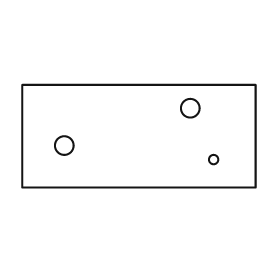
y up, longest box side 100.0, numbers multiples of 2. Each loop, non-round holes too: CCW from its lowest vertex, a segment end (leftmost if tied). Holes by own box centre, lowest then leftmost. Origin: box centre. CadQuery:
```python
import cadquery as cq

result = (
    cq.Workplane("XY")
    .moveTo(-50.0, -22.0)
    .lineTo(50.0, -22.0)
    .lineTo(50.0, 22.0)
    .lineTo(-50.0, 22.0)
    .close()
    .moveTo(32.0, -10.0)
    .circle(2.0)
    .moveTo(-32.0, -4.0)
    .circle(4.0)
    .moveTo(22.0, 12.0)
    .circle(4.0)
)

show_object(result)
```